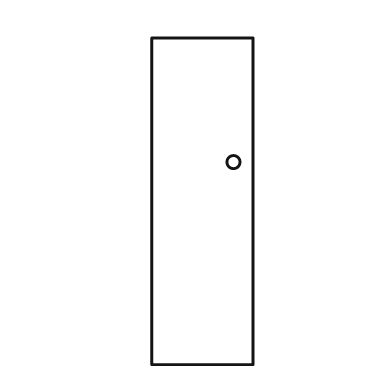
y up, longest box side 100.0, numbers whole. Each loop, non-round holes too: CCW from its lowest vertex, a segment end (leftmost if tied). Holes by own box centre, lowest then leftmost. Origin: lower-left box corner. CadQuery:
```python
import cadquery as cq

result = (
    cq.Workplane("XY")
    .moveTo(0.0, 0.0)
    .lineTo(31.0, 0.0)
    .lineTo(31.0, 100.0)
    .lineTo(0.0, 100.0)
    .close()
    .moveTo(25.0, 62.0)
    .circle(2.0)
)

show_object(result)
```